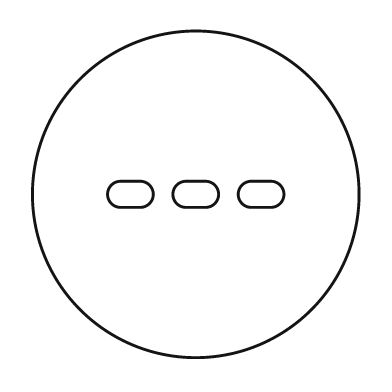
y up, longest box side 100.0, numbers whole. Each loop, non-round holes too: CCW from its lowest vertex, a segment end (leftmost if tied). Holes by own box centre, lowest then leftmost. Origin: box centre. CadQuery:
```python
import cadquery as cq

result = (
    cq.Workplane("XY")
    .moveTo(0.0, 0.0)
    .circle(50.0)
    .moveTo(-23.0, -4.0)
    .lineTo(-17.0, -4.0)
    .threePointArc((-13.0, 0.0), (-17.0, 4.0))
    .lineTo(-23.0, 4.0)
    .threePointArc((-27.0, 0.0), (-23.0, -4.0))
    .close()
    .moveTo(-3.0, -4.0)
    .lineTo(3.0, -4.0)
    .threePointArc((7.0, 0.0), (3.0, 4.0))
    .lineTo(-3.0, 4.0)
    .threePointArc((-7.0, 0.0), (-3.0, -4.0))
    .close()
    .moveTo(17.0, -4.0)
    .lineTo(23.0, -4.0)
    .threePointArc((27.0, 0.0), (23.0, 4.0))
    .lineTo(17.0, 4.0)
    .threePointArc((13.0, 0.0), (17.0, -4.0))
    .close()
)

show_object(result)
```